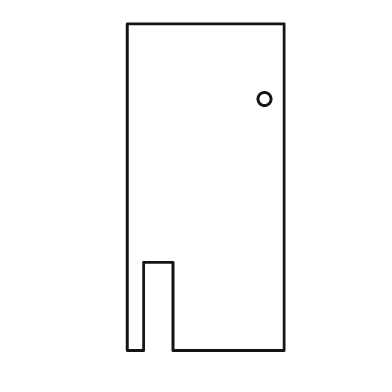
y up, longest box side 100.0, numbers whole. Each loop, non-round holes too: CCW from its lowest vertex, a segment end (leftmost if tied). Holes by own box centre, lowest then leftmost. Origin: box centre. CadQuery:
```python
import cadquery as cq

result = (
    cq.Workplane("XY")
    .moveTo(-24.0, -50.0)
    .lineTo(-19.0, -50.0)
    .lineTo(-19.0, -23.0)
    .lineTo(-10.0, -23.0)
    .lineTo(-10.0, -50.0)
    .lineTo(24.0, -50.0)
    .lineTo(24.0, 50.0)
    .lineTo(-24.0, 50.0)
    .close()
    .moveTo(18.0, 27.0)
    .circle(2.0)
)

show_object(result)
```